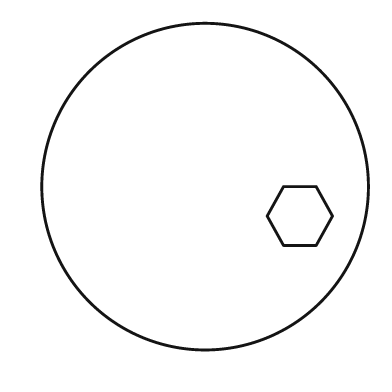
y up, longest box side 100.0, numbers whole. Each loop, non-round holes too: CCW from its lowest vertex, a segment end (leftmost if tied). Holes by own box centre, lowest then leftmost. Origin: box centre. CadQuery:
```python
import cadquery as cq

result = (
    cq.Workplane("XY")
    .moveTo(0.0, 0.0)
    .circle(50.0)
    .moveTo(24.0, -18.0)
    .lineTo(34.0, -18.0)
    .lineTo(39.0, -9.0)
    .lineTo(34.0, 0.0)
    .lineTo(24.0, 0.0)
    .lineTo(19.0, -9.0)
    .close()
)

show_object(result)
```